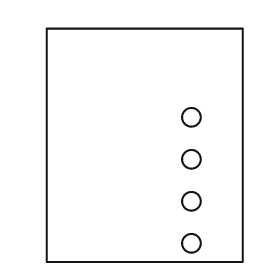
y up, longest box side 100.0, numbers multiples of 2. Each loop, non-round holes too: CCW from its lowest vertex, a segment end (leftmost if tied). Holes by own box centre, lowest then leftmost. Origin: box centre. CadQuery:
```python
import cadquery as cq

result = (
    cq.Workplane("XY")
    .moveTo(-42.0, -50.0)
    .lineTo(42.0, -50.0)
    .lineTo(42.0, 50.0)
    .lineTo(-42.0, 50.0)
    .close()
    .moveTo(20.0, -42.0)
    .circle(4.0)
    .moveTo(20.0, -24.0)
    .circle(4.0)
    .moveTo(20.0, -6.0)
    .circle(4.0)
    .moveTo(20.0, 12.0)
    .circle(4.0)
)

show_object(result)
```